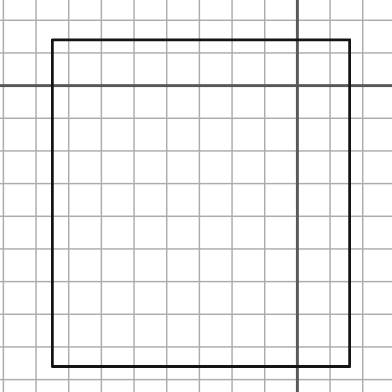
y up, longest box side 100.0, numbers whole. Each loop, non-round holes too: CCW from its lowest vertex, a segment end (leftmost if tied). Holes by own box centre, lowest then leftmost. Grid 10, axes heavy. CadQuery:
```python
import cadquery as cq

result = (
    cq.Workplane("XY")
    .moveTo(-75.0, -86.0)
    .lineTo(16.0, -86.0)
    .lineTo(16.0, 14.0)
    .lineTo(-75.0, 14.0)
    .close()
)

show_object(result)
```